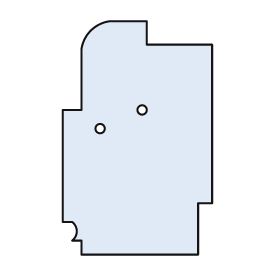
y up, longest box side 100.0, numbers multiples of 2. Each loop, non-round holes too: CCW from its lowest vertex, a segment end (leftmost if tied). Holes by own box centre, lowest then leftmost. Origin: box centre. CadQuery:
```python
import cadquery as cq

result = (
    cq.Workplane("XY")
    .moveTo(-24.0, -50.0)
    .lineTo(26.0, -50.0)
    .lineTo(26.0, -28.0)
    .lineTo(32.0, -28.0)
    .lineTo(32.0, 40.0)
    .lineTo(4.0, 40.0)
    .lineTo(4.0, 50.0)
    .lineTo(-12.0, 50.0)
    .threePointArc((-20.0, 46.0), (-24.0, 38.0))
    .lineTo(-24.0, 12.0)
    .lineTo(-32.0, 12.0)
    .lineTo(-32.0, -36.0)
    .lineTo(-28.0, -36.0)
    .threePointArc((-26.0, -40.0), (-28.0, -44.0))
    .lineTo(-24.0, -44.0)
    .close()
    .moveTo(-16.0, 4.0)
    .circle(2.0)
    .moveTo(2.0, 12.0)
    .circle(2.0)
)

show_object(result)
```